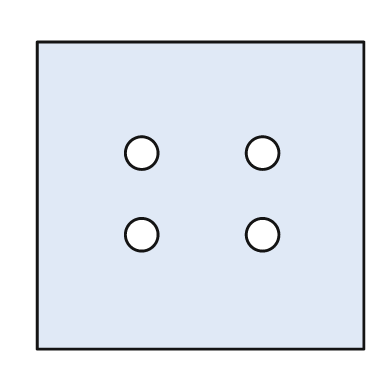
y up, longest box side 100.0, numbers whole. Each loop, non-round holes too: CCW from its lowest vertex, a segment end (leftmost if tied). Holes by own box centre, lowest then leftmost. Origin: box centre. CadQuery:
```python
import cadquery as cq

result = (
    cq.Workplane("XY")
    .moveTo(-50.0, -47.0)
    .lineTo(50.0, -47.0)
    .lineTo(50.0, 47.0)
    .lineTo(-50.0, 47.0)
    .close()
    .moveTo(-18.0, -12.0)
    .circle(5.0)
    .moveTo(19.0, -12.0)
    .circle(5.0)
    .moveTo(-18.0, 13.0)
    .circle(5.0)
    .moveTo(19.0, 13.0)
    .circle(5.0)
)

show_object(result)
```